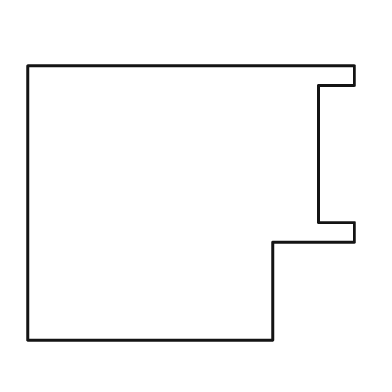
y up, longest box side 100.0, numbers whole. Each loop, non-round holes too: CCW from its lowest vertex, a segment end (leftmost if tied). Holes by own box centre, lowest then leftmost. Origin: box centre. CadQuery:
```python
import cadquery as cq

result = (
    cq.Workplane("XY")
    .moveTo(-50.0, -42.0)
    .lineTo(25.0, -42.0)
    .lineTo(25.0, -12.0)
    .lineTo(50.0, -12.0)
    .lineTo(50.0, -6.0)
    .lineTo(39.0, -6.0)
    .lineTo(39.0, 36.0)
    .lineTo(50.0, 36.0)
    .lineTo(50.0, 42.0)
    .lineTo(-50.0, 42.0)
    .close()
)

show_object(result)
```